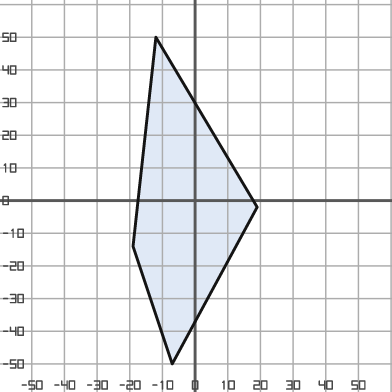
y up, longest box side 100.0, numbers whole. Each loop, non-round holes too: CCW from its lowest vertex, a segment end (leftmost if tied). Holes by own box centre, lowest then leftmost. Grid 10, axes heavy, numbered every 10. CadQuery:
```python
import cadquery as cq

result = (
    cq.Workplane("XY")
    .moveTo(-7.0, -50.0)
    .lineTo(19.0, -2.0)
    .lineTo(-12.0, 50.0)
    .lineTo(-19.0, -14.0)
    .close()
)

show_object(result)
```